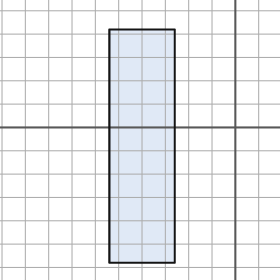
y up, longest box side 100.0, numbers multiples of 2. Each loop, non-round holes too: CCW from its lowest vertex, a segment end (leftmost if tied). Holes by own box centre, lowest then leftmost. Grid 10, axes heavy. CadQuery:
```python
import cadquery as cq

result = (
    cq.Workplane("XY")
    .moveTo(-54.0, -58.0)
    .lineTo(-26.0, -58.0)
    .lineTo(-26.0, 42.0)
    .lineTo(-54.0, 42.0)
    .close()
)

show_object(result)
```